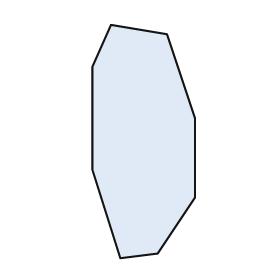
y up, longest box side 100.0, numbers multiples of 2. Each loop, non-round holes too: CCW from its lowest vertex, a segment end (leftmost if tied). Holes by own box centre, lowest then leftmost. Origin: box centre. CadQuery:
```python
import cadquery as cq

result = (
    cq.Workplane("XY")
    .moveTo(-10.0, -50.0)
    .lineTo(6.0, -48.0)
    .lineTo(22.0, -24.0)
    .lineTo(22.0, 10.0)
    .lineTo(10.0, 46.0)
    .lineTo(-14.0, 50.0)
    .lineTo(-22.0, 32.0)
    .lineTo(-22.0, -12.0)
    .close()
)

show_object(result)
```